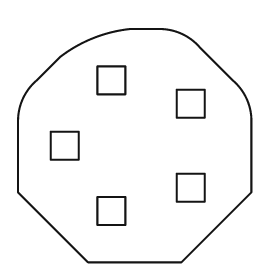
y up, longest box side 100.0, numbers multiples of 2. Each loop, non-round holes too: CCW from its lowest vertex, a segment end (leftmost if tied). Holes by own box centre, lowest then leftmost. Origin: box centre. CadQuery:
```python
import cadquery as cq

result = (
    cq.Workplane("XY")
    .moveTo(-20.0, -50.0)
    .lineTo(20.0, -50.0)
    .lineTo(50.0, -20.0)
    .lineTo(50.0, 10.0)
    .threePointArc((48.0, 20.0), (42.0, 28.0))
    .lineTo(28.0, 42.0)
    .threePointArc((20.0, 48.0), (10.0, 50.0))
    .lineTo(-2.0, 50.0)
    .threePointArc((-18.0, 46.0), (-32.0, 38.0))
    .lineTo(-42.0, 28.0)
    .threePointArc((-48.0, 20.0), (-50.0, 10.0))
    .lineTo(-50.0, -20.0)
    .close()
    .moveTo(-16.0, -34.0)
    .lineTo(-4.0, -34.0)
    .lineTo(-4.0, -22.0)
    .lineTo(-16.0, -22.0)
    .close()
    .moveTo(18.0, -24.0)
    .lineTo(30.0, -24.0)
    .lineTo(30.0, -12.0)
    .lineTo(18.0, -12.0)
    .close()
    .moveTo(-36.0, -6.0)
    .lineTo(-24.0, -6.0)
    .lineTo(-24.0, 6.0)
    .lineTo(-36.0, 6.0)
    .close()
    .moveTo(18.0, 12.0)
    .lineTo(30.0, 12.0)
    .lineTo(30.0, 24.0)
    .lineTo(18.0, 24.0)
    .close()
    .moveTo(-16.0, 22.0)
    .lineTo(-4.0, 22.0)
    .lineTo(-4.0, 34.0)
    .lineTo(-16.0, 34.0)
    .close()
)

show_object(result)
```